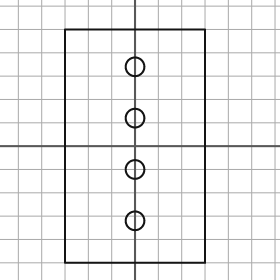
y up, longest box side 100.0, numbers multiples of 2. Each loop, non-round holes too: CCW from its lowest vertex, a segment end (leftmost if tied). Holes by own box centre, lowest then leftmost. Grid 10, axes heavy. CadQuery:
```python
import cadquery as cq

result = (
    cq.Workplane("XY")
    .moveTo(-30.0, -50.0)
    .lineTo(30.0, -50.0)
    .lineTo(30.0, 50.0)
    .lineTo(-30.0, 50.0)
    .close()
    .moveTo(0.0, -32.0)
    .circle(4.0)
    .moveTo(0.0, -10.0)
    .circle(4.0)
    .moveTo(0.0, 12.0)
    .circle(4.0)
    .moveTo(0.0, 34.0)
    .circle(4.0)
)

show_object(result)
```